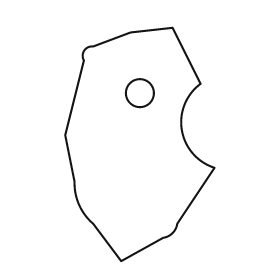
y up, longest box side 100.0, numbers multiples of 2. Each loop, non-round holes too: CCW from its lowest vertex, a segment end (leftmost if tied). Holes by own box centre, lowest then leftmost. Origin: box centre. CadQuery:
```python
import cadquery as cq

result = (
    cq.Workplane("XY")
    .moveTo(-8.0, -50.0)
    .lineTo(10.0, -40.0)
    .threePointArc((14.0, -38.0), (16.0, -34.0))
    .lineTo(32.0, -10.0)
    .threePointArc((18.0, 6.0), (26.0, 26.0))
    .lineTo(14.0, 50.0)
    .lineTo(-4.0, 48.0)
    .lineTo(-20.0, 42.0)
    .threePointArc((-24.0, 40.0), (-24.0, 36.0))
    .lineTo(-32.0, 4.0)
    .lineTo(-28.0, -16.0)
    .threePointArc((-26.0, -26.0), (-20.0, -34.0))
    .close()
    .moveTo(0.0, 22.0)
    .circle(6.0)
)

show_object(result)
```